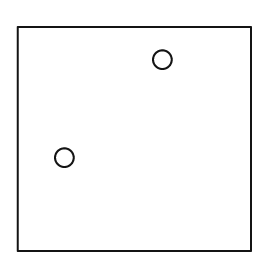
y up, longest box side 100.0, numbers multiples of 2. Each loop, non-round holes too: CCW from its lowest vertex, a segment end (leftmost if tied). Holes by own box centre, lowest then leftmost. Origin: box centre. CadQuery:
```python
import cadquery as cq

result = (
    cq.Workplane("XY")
    .moveTo(-50.0, -48.0)
    .lineTo(50.0, -48.0)
    .lineTo(50.0, 48.0)
    .lineTo(-50.0, 48.0)
    .close()
    .moveTo(-30.0, -8.0)
    .circle(4.0)
    .moveTo(12.0, 34.0)
    .circle(4.0)
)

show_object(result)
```